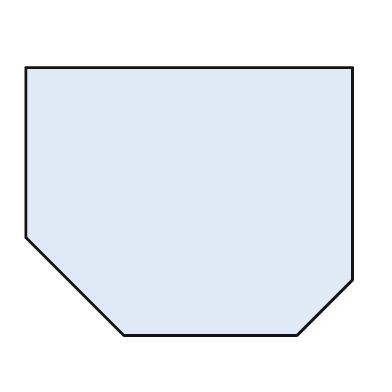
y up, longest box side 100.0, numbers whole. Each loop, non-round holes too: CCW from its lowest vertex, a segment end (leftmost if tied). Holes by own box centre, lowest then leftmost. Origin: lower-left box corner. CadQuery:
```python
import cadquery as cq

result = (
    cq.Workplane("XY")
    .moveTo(30.0, 0.0)
    .lineTo(83.0, 0.0)
    .lineTo(100.0, 17.0)
    .lineTo(100.0, 82.0)
    .lineTo(0.0, 82.0)
    .lineTo(0.0, 30.0)
    .close()
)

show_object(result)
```